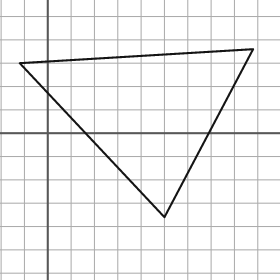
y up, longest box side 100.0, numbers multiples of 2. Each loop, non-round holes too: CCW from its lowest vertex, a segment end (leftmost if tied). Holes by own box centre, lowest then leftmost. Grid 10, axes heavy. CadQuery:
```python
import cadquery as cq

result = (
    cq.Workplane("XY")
    .moveTo(50.0, -36.0)
    .lineTo(88.0, 36.0)
    .lineTo(-12.0, 30.0)
    .close()
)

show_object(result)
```